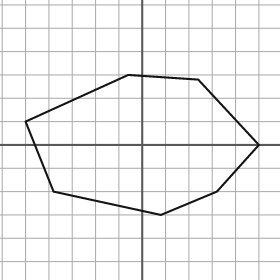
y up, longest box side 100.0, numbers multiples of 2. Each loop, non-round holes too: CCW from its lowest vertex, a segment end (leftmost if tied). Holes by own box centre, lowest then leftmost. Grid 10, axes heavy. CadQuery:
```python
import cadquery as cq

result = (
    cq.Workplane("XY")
    .moveTo(8.0, -30.0)
    .lineTo(32.0, -20.0)
    .lineTo(50.0, 0.0)
    .lineTo(24.0, 28.0)
    .lineTo(-6.0, 30.0)
    .lineTo(-50.0, 10.0)
    .lineTo(-38.0, -20.0)
    .close()
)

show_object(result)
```